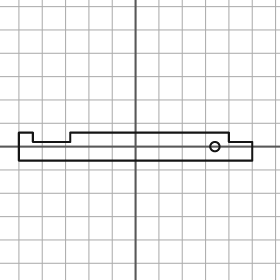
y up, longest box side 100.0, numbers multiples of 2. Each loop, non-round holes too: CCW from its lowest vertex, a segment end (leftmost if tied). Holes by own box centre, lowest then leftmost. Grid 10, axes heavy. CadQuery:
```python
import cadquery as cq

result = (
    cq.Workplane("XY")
    .moveTo(-50.0, -6.0)
    .lineTo(50.0, -6.0)
    .lineTo(50.0, 2.0)
    .lineTo(40.0, 2.0)
    .lineTo(40.0, 6.0)
    .lineTo(-28.0, 6.0)
    .lineTo(-28.0, 2.0)
    .lineTo(-44.0, 2.0)
    .lineTo(-44.0, 6.0)
    .lineTo(-50.0, 6.0)
    .close()
    .moveTo(34.0, 0.0)
    .circle(2.0)
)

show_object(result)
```